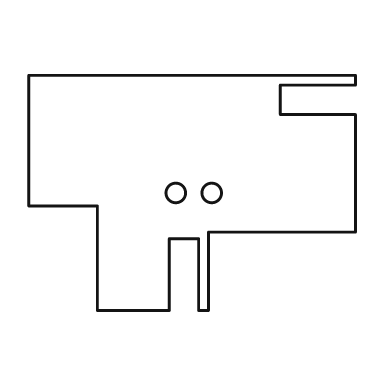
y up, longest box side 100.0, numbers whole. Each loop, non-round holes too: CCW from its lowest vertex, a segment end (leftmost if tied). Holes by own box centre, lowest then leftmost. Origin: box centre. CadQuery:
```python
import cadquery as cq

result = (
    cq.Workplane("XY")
    .moveTo(-29.0, -36.0)
    .lineTo(-7.0, -36.0)
    .lineTo(-7.0, -14.0)
    .lineTo(2.0, -14.0)
    .lineTo(2.0, -36.0)
    .lineTo(5.0, -36.0)
    .lineTo(5.0, -12.0)
    .lineTo(50.0, -12.0)
    .lineTo(50.0, 24.0)
    .lineTo(27.0, 24.0)
    .lineTo(27.0, 33.0)
    .lineTo(50.0, 33.0)
    .lineTo(50.0, 36.0)
    .lineTo(-50.0, 36.0)
    .lineTo(-50.0, -4.0)
    .lineTo(-29.0, -4.0)
    .close()
    .moveTo(-5.0, 0.0)
    .circle(3.0)
    .moveTo(6.0, 0.0)
    .circle(3.0)
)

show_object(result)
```